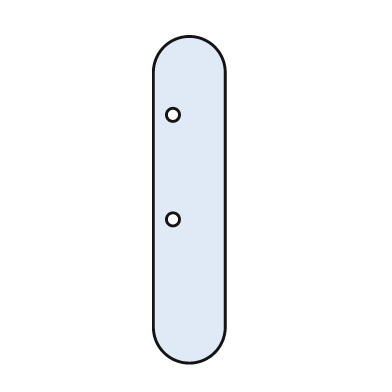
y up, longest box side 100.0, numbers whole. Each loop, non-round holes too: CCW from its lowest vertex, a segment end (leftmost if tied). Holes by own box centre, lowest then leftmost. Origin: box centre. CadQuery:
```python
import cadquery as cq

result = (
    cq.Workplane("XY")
    .moveTo(-11.0, -39.0)
    .threePointArc((0.0, -50.0), (11.0, -39.0))
    .lineTo(11.0, 39.0)
    .threePointArc((0.0, 50.0), (-11.0, 39.0))
    .close()
    .moveTo(-5.0, -6.0)
    .circle(2.0)
    .moveTo(-5.0, 26.0)
    .circle(2.0)
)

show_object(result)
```